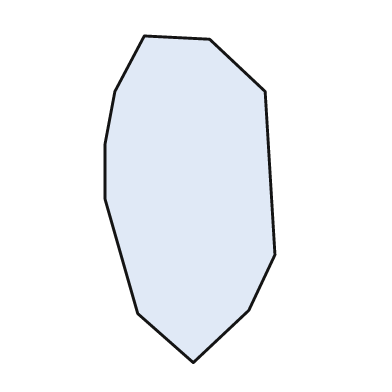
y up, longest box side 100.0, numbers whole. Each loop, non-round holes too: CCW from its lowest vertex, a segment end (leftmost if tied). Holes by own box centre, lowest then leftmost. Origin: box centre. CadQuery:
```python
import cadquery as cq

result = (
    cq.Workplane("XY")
    .moveTo(1.0, -50.0)
    .lineTo(18.0, -34.0)
    .lineTo(26.0, -17.0)
    .lineTo(23.0, 33.0)
    .lineTo(6.0, 49.0)
    .lineTo(-14.0, 50.0)
    .lineTo(-23.0, 33.0)
    .lineTo(-26.0, 17.0)
    .lineTo(-26.0, 0.0)
    .lineTo(-16.0, -35.0)
    .close()
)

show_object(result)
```